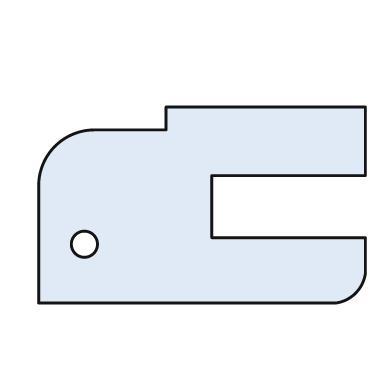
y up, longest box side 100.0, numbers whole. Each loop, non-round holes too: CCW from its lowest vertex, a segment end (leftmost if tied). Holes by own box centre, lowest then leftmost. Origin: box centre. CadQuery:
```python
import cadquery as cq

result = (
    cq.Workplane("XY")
    .moveTo(-50.0, -30.0)
    .lineTo(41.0, -30.0)
    .threePointArc((47.0, -27.0), (50.0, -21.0))
    .lineTo(50.0, -10.0)
    .lineTo(3.0, -10.0)
    .lineTo(3.0, 9.0)
    .lineTo(50.0, 9.0)
    .lineTo(50.0, 30.0)
    .lineTo(-11.0, 30.0)
    .lineTo(-11.0, 23.0)
    .lineTo(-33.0, 23.0)
    .threePointArc((-45.0, 18.0), (-50.0, 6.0))
    .close()
    .moveTo(-36.0, -12.0)
    .circle(4.0)
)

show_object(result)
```